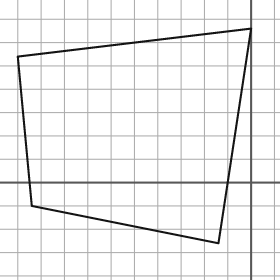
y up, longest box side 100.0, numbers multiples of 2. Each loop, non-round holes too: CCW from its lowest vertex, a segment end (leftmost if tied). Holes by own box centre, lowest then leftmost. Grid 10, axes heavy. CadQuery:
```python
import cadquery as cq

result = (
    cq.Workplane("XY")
    .moveTo(-14.0, -26.0)
    .lineTo(0.0, 66.0)
    .lineTo(-100.0, 54.0)
    .lineTo(-94.0, -10.0)
    .close()
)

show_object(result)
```